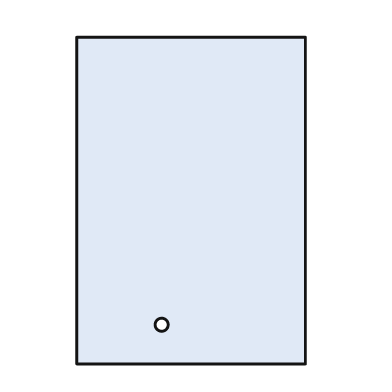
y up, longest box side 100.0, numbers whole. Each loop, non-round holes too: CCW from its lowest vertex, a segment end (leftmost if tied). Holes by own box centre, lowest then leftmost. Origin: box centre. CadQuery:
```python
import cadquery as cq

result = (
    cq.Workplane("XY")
    .moveTo(-35.0, -50.0)
    .lineTo(35.0, -50.0)
    .lineTo(35.0, 50.0)
    .lineTo(-35.0, 50.0)
    .close()
    .moveTo(-9.0, -38.0)
    .circle(2.0)
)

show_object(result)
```